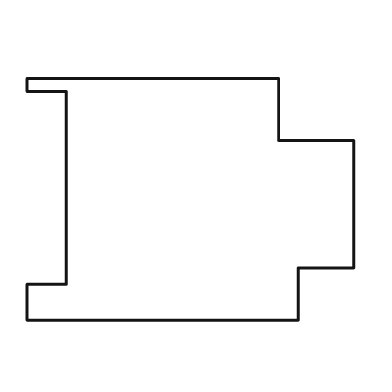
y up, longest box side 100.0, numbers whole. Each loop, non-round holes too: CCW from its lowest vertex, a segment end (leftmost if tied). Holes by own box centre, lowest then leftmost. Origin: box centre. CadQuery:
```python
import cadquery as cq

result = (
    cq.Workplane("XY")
    .moveTo(-50.0, -37.0)
    .lineTo(33.0, -37.0)
    .lineTo(33.0, -21.0)
    .lineTo(50.0, -21.0)
    .lineTo(50.0, 18.0)
    .lineTo(27.0, 18.0)
    .lineTo(27.0, 37.0)
    .lineTo(-50.0, 37.0)
    .lineTo(-50.0, 33.0)
    .lineTo(-38.0, 33.0)
    .lineTo(-38.0, -26.0)
    .lineTo(-50.0, -26.0)
    .close()
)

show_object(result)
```